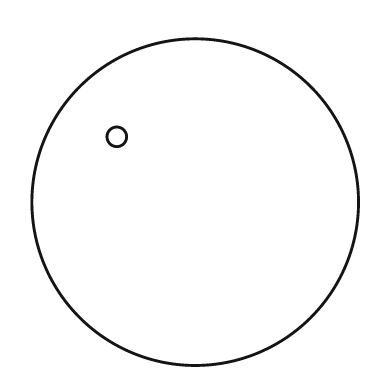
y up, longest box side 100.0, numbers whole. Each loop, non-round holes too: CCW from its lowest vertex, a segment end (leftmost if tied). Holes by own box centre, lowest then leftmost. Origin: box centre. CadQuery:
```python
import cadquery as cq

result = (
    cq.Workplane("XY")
    .moveTo(0.0, 0.0)
    .circle(50.0)
    .moveTo(-24.0, 20.0)
    .circle(3.0)
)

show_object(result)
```